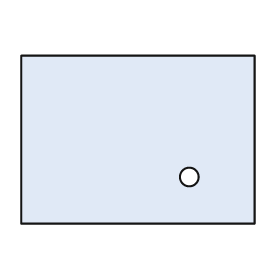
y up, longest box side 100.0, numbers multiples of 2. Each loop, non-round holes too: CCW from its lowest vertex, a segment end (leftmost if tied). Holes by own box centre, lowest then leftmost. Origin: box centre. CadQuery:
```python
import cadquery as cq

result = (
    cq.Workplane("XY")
    .moveTo(-50.0, -36.0)
    .lineTo(50.0, -36.0)
    .lineTo(50.0, 36.0)
    .lineTo(-50.0, 36.0)
    .close()
    .moveTo(22.0, -16.0)
    .circle(4.0)
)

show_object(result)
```